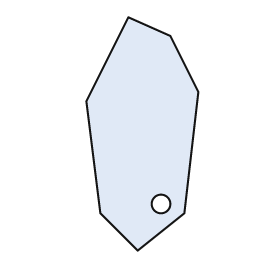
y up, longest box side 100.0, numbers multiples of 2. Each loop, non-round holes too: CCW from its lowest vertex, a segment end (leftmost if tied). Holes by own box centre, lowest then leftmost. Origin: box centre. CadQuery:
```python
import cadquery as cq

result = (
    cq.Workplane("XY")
    .moveTo(-2.0, -50.0)
    .lineTo(18.0, -34.0)
    .lineTo(24.0, 18.0)
    .lineTo(12.0, 42.0)
    .lineTo(-6.0, 50.0)
    .lineTo(-24.0, 14.0)
    .lineTo(-18.0, -34.0)
    .close()
    .moveTo(8.0, -30.0)
    .circle(4.0)
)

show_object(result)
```